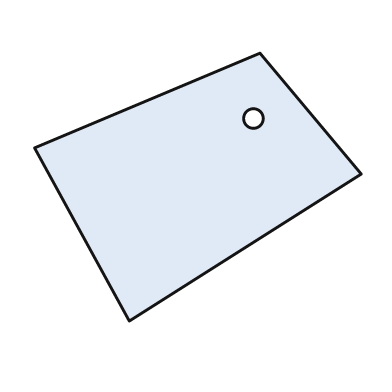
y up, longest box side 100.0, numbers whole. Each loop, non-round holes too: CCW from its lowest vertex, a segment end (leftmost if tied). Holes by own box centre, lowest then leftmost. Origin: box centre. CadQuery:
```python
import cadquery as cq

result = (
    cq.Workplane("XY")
    .moveTo(-21.0, -41.0)
    .lineTo(50.0, 4.0)
    .lineTo(19.0, 41.0)
    .lineTo(-50.0, 12.0)
    .close()
    .moveTo(17.0, 21.0)
    .circle(3.0)
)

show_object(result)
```